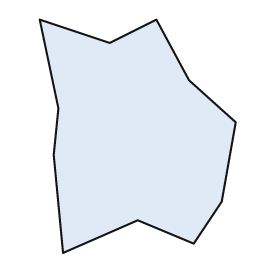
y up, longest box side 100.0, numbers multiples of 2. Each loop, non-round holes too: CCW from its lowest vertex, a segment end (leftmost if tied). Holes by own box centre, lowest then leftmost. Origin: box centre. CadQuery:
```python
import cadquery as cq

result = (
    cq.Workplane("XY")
    .moveTo(-32.0, -50.0)
    .lineTo(0.0, -36.0)
    .lineTo(24.0, -46.0)
    .lineTo(36.0, -28.0)
    .lineTo(42.0, 6.0)
    .lineTo(22.0, 24.0)
    .lineTo(8.0, 50.0)
    .lineTo(-12.0, 40.0)
    .lineTo(-42.0, 50.0)
    .lineTo(-34.0, 12.0)
    .lineTo(-36.0, -8.0)
    .close()
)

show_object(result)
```